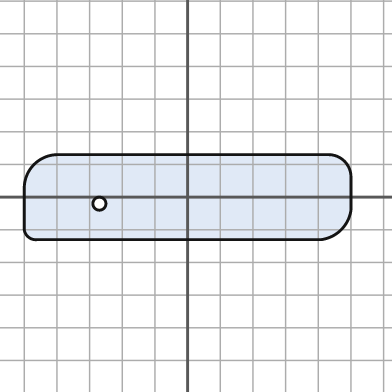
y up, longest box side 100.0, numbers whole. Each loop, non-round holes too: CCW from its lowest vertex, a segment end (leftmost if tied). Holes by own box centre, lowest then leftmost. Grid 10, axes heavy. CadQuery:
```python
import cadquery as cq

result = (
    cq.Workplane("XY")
    .moveTo(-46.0, -13.0)
    .lineTo(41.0, -13.0)
    .threePointArc((47.0, -10.0), (50.0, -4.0))
    .lineTo(50.0, 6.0)
    .threePointArc((48.0, 11.0), (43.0, 13.0))
    .lineTo(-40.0, 13.0)
    .threePointArc((-47.0, 10.0), (-50.0, 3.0))
    .lineTo(-50.0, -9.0)
    .threePointArc((-49.0, -12.0), (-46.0, -13.0))
    .close()
    .moveTo(-27.0, -2.0)
    .circle(2.0)
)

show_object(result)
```